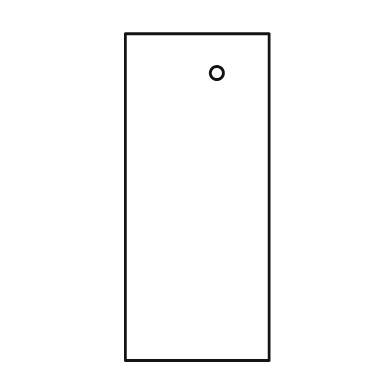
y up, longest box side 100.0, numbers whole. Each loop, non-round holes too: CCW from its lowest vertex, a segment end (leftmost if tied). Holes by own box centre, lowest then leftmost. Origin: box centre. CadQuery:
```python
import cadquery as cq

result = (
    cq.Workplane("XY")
    .moveTo(-22.0, -50.0)
    .lineTo(22.0, -50.0)
    .lineTo(22.0, 50.0)
    .lineTo(-22.0, 50.0)
    .close()
    .moveTo(6.0, 38.0)
    .circle(2.0)
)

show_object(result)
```